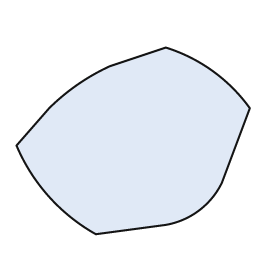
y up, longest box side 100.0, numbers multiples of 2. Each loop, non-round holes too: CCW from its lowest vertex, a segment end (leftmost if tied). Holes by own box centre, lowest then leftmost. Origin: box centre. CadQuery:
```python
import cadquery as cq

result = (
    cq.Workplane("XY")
    .moveTo(-16.0, -40.0)
    .lineTo(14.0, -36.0)
    .threePointArc((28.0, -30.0), (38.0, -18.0))
    .lineTo(50.0, 14.0)
    .threePointArc((34.0, 30.0), (14.0, 40.0))
    .lineTo(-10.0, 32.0)
    .threePointArc((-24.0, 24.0), (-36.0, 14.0))
    .lineTo(-50.0, -2.0)
    .threePointArc((-36.0, -24.0), (-16.0, -40.0))
    .close()
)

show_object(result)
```